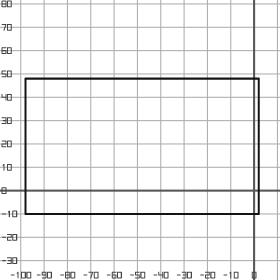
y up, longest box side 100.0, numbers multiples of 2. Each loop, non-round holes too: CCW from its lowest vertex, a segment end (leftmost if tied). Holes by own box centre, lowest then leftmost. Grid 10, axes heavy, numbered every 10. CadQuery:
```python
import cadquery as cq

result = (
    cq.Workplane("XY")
    .moveTo(-98.0, -10.0)
    .lineTo(2.0, -10.0)
    .lineTo(2.0, 48.0)
    .lineTo(-98.0, 48.0)
    .close()
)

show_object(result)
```